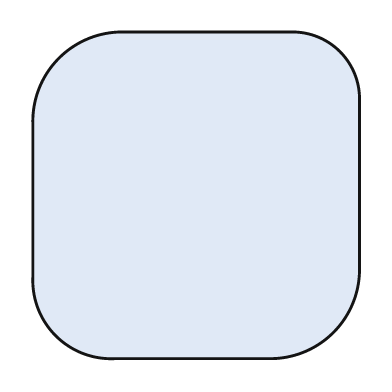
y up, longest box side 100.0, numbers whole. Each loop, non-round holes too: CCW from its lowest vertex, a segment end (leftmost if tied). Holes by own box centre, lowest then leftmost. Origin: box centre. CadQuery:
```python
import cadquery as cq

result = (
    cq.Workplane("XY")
    .moveTo(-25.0, -50.0)
    .lineTo(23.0, -50.0)
    .threePointArc((42.0, -42.0), (50.0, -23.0))
    .lineTo(50.0, 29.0)
    .threePointArc((44.0, 44.0), (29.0, 50.0))
    .lineTo(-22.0, 50.0)
    .threePointArc((-42.0, 42.0), (-50.0, 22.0))
    .lineTo(-50.0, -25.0)
    .threePointArc((-43.0, -43.0), (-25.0, -50.0))
    .close()
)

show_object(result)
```